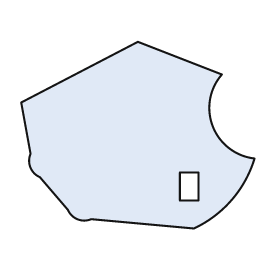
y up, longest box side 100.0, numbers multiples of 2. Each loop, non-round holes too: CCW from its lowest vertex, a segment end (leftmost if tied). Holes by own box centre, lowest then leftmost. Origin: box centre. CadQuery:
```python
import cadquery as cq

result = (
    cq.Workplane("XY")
    .moveTo(24.0, -40.0)
    .threePointArc((40.0, -28.0), (50.0, -10.0))
    .threePointArc((32.0, 4.0), (36.0, 26.0))
    .lineTo(0.0, 40.0)
    .lineTo(-50.0, 14.0)
    .lineTo(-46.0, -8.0)
    .threePointArc((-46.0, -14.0), (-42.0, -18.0))
    .lineTo(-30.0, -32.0)
    .threePointArc((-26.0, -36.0), (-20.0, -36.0))
    .close()
    .moveTo(18.0, -28.0)
    .lineTo(26.0, -28.0)
    .lineTo(26.0, -16.0)
    .lineTo(18.0, -16.0)
    .close()
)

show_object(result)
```